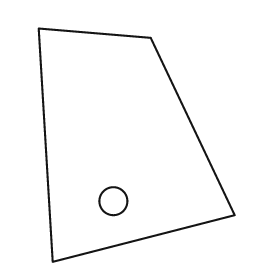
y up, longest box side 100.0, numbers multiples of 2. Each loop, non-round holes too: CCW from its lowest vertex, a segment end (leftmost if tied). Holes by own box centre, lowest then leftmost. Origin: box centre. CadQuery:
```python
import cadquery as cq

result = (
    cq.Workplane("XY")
    .moveTo(-36.0, -50.0)
    .lineTo(42.0, -30.0)
    .lineTo(6.0, 46.0)
    .lineTo(-42.0, 50.0)
    .close()
    .moveTo(-10.0, -24.0)
    .circle(6.0)
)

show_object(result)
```